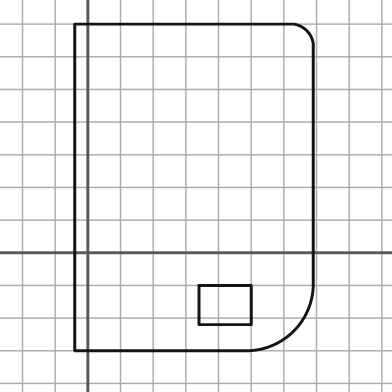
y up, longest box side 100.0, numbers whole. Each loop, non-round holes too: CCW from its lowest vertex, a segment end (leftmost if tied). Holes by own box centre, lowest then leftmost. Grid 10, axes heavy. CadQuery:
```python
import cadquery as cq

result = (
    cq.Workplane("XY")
    .moveTo(-4.0, -30.0)
    .lineTo(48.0, -30.0)
    .threePointArc((63.0, -24.0), (69.0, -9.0))
    .lineTo(69.0, 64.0)
    .threePointArc((67.0, 68.0), (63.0, 70.0))
    .lineTo(-4.0, 70.0)
    .close()
    .moveTo(34.0, -22.0)
    .lineTo(50.0, -22.0)
    .lineTo(50.0, -10.0)
    .lineTo(34.0, -10.0)
    .close()
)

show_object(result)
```